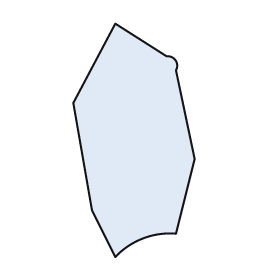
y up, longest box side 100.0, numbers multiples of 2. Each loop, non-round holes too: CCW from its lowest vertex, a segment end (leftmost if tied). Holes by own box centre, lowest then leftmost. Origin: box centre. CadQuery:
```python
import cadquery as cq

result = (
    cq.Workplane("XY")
    .moveTo(-8.0, -50.0)
    .threePointArc((4.0, -42.0), (18.0, -40.0))
    .lineTo(26.0, -8.0)
    .lineTo(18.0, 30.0)
    .threePointArc((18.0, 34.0), (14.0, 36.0))
    .lineTo(-8.0, 50.0)
    .lineTo(-26.0, 16.0)
    .lineTo(-18.0, -30.0)
    .close()
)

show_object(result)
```